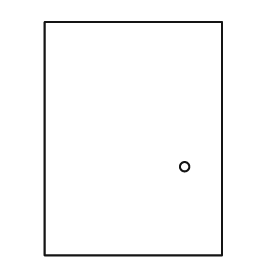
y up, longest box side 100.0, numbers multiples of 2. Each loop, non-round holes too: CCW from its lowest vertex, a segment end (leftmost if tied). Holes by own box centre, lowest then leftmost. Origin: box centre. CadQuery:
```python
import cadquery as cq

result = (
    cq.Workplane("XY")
    .moveTo(-38.0, -50.0)
    .lineTo(38.0, -50.0)
    .lineTo(38.0, 50.0)
    .lineTo(-38.0, 50.0)
    .close()
    .moveTo(22.0, -12.0)
    .circle(2.0)
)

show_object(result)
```